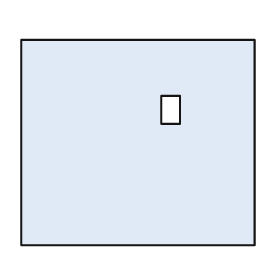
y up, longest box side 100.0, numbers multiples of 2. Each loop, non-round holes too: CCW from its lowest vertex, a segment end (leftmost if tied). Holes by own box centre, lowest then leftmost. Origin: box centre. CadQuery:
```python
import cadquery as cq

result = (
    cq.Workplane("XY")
    .moveTo(-50.0, -44.0)
    .lineTo(50.0, -44.0)
    .lineTo(50.0, 44.0)
    .lineTo(-50.0, 44.0)
    .close()
    .moveTo(10.0, 8.0)
    .lineTo(18.0, 8.0)
    .lineTo(18.0, 20.0)
    .lineTo(10.0, 20.0)
    .close()
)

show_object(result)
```